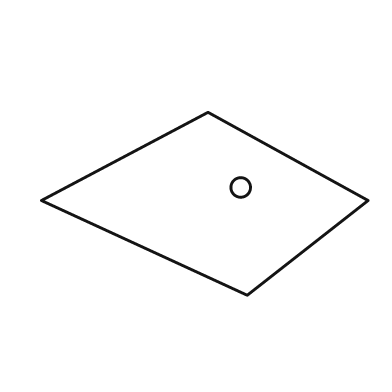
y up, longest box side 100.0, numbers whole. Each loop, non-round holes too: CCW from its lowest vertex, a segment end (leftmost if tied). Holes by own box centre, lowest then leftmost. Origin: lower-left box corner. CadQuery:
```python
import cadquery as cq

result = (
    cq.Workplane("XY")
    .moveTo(63.0, 0.0)
    .lineTo(100.0, 29.0)
    .lineTo(51.0, 56.0)
    .lineTo(0.0, 29.0)
    .close()
    .moveTo(61.0, 33.0)
    .circle(3.0)
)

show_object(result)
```